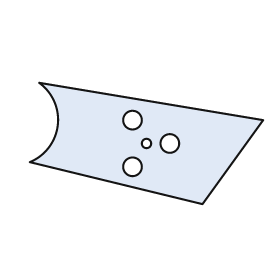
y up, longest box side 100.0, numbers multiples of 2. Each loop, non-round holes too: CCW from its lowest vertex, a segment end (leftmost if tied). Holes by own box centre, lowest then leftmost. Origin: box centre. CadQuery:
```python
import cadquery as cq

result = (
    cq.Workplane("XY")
    .moveTo(24.0, -26.0)
    .lineTo(50.0, 10.0)
    .lineTo(-46.0, 26.0)
    .threePointArc((-38.0, 8.0), (-50.0, -8.0))
    .close()
    .moveTo(-6.0, -10.0)
    .circle(4.0)
    .moveTo(0.0, 0.0)
    .circle(2.0)
    .moveTo(10.0, 0.0)
    .circle(4.0)
    .moveTo(-6.0, 10.0)
    .circle(4.0)
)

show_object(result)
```